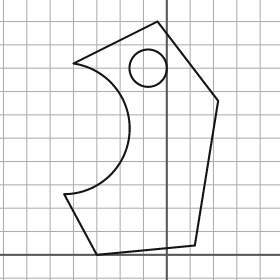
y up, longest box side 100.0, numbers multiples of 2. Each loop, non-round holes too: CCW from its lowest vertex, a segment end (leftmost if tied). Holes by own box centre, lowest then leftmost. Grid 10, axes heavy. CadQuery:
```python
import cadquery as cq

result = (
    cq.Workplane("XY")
    .moveTo(-30.0, 0.0)
    .lineTo(12.0, 4.0)
    .lineTo(22.0, 66.0)
    .lineTo(-4.0, 100.0)
    .lineTo(-40.0, 82.0)
    .threePointArc((-16.0, 52.0), (-44.0, 26.0))
    .close()
    .moveTo(-8.0, 80.0)
    .circle(8.0)
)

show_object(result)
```